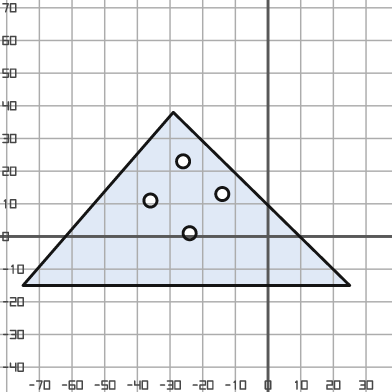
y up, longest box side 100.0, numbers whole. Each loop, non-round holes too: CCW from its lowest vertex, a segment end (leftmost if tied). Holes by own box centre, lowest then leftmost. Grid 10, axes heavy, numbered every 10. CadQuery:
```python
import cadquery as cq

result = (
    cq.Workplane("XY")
    .moveTo(-75.0, -15.0)
    .lineTo(25.0, -15.0)
    .lineTo(-29.0, 38.0)
    .close()
    .moveTo(-24.0, 1.0)
    .circle(2.0)
    .moveTo(-36.0, 11.0)
    .circle(2.0)
    .moveTo(-14.0, 13.0)
    .circle(2.0)
    .moveTo(-26.0, 23.0)
    .circle(2.0)
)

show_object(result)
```